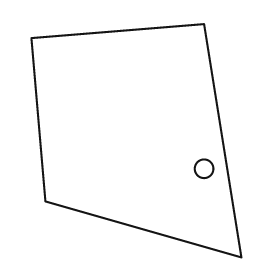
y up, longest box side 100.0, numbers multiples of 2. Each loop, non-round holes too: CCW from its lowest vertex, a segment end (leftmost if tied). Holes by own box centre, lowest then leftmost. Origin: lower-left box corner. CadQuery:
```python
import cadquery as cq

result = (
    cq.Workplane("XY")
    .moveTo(90.0, 0.0)
    .lineTo(74.0, 100.0)
    .lineTo(0.0, 94.0)
    .lineTo(6.0, 24.0)
    .close()
    .moveTo(74.0, 38.0)
    .circle(4.0)
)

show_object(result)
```